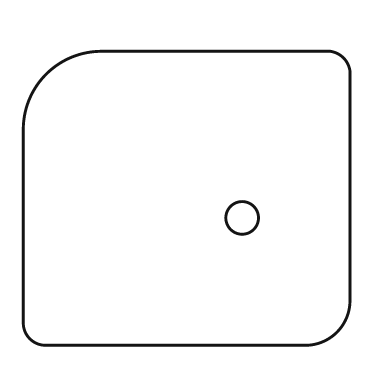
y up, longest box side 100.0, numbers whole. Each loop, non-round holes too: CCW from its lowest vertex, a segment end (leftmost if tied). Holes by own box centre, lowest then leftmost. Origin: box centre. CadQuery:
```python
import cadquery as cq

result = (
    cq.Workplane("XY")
    .moveTo(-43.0, -45.0)
    .lineTo(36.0, -45.0)
    .threePointArc((46.0, -41.0), (50.0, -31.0))
    .lineTo(50.0, 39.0)
    .threePointArc((48.0, 43.0), (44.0, 45.0))
    .lineTo(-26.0, 45.0)
    .threePointArc((-43.0, 38.0), (-50.0, 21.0))
    .lineTo(-50.0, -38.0)
    .threePointArc((-48.0, -43.0), (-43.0, -45.0))
    .close()
    .moveTo(17.0, -6.0)
    .circle(5.0)
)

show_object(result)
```